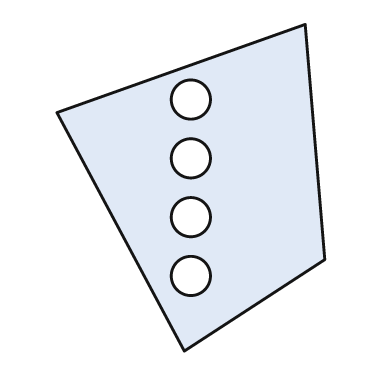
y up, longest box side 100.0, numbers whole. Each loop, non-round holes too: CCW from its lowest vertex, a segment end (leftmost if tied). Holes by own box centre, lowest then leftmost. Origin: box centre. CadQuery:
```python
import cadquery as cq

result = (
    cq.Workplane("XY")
    .moveTo(-2.0, -50.0)
    .lineTo(41.0, -22.0)
    .lineTo(35.0, 50.0)
    .lineTo(-41.0, 23.0)
    .close()
    .moveTo(0.0, -27.0)
    .circle(6.0)
    .moveTo(0.0, -9.0)
    .circle(6.0)
    .moveTo(0.0, 9.0)
    .circle(6.0)
    .moveTo(0.0, 27.0)
    .circle(6.0)
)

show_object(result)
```